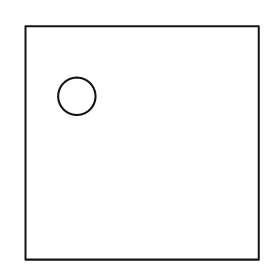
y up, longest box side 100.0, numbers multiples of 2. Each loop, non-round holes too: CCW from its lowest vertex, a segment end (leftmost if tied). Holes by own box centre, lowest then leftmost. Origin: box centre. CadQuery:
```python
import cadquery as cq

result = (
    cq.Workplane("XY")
    .moveTo(-50.0, -50.0)
    .lineTo(50.0, -50.0)
    .lineTo(50.0, 50.0)
    .lineTo(-50.0, 50.0)
    .close()
    .moveTo(-28.0, 20.0)
    .circle(8.0)
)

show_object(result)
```